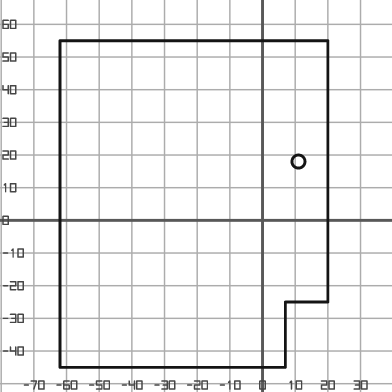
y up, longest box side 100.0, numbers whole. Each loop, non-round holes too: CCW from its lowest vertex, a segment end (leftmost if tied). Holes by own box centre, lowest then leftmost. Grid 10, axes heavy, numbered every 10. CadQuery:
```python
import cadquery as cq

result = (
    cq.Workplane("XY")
    .moveTo(-62.0, -45.0)
    .lineTo(7.0, -45.0)
    .lineTo(7.0, -25.0)
    .lineTo(20.0, -25.0)
    .lineTo(20.0, 55.0)
    .lineTo(-62.0, 55.0)
    .close()
    .moveTo(11.0, 18.0)
    .circle(2.0)
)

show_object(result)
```